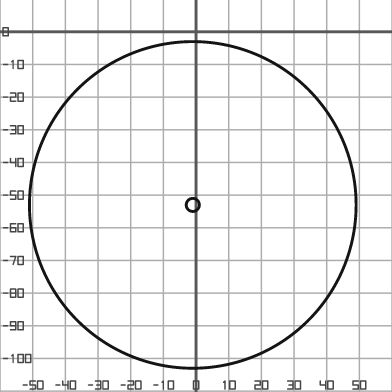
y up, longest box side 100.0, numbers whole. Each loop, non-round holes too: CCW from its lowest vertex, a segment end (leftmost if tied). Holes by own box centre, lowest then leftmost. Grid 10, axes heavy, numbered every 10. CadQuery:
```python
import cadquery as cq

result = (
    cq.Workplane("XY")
    .moveTo(-1.0, -53.0)
    .circle(50.0)
    .moveTo(-1.0, -53.0)
    .circle(2.0)
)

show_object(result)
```